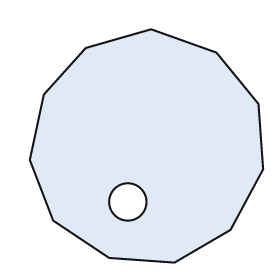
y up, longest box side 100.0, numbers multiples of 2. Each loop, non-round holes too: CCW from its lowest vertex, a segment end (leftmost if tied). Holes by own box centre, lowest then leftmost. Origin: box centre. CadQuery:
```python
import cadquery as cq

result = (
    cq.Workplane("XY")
    .moveTo(12.0, -50.0)
    .lineTo(36.0, -36.0)
    .lineTo(50.0, -10.0)
    .lineTo(48.0, 18.0)
    .lineTo(30.0, 40.0)
    .lineTo(2.0, 50.0)
    .lineTo(-26.0, 42.0)
    .lineTo(-44.0, 22.0)
    .lineTo(-50.0, -6.0)
    .lineTo(-40.0, -32.0)
    .lineTo(-16.0, -48.0)
    .close()
    .moveTo(-8.0, -24.0)
    .circle(8.0)
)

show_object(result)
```